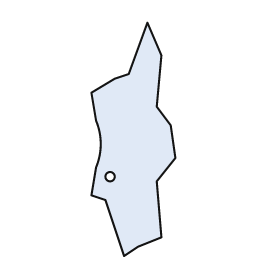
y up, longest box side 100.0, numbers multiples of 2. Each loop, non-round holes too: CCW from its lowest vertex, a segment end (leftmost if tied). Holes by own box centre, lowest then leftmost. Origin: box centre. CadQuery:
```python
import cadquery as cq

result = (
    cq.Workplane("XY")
    .moveTo(-4.0, -50.0)
    .lineTo(2.0, -46.0)
    .lineTo(12.0, -42.0)
    .lineTo(10.0, -18.0)
    .lineTo(18.0, -8.0)
    .lineTo(16.0, 6.0)
    .lineTo(10.0, 14.0)
    .lineTo(12.0, 36.0)
    .lineTo(6.0, 50.0)
    .lineTo(-2.0, 28.0)
    .lineTo(-8.0, 26.0)
    .lineTo(-18.0, 20.0)
    .lineTo(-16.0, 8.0)
    .threePointArc((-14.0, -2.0), (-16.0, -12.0))
    .lineTo(-18.0, -24.0)
    .lineTo(-12.0, -26.0)
    .close()
    .moveTo(-10.0, -16.0)
    .circle(2.0)
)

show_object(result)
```